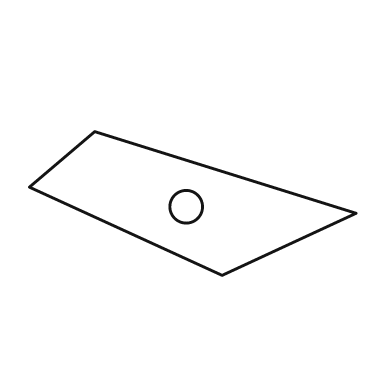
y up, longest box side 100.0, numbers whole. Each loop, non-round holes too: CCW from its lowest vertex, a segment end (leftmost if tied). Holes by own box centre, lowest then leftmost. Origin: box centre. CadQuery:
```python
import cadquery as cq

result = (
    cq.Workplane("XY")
    .moveTo(9.0, -22.0)
    .lineTo(50.0, -3.0)
    .lineTo(-30.0, 22.0)
    .lineTo(-50.0, 5.0)
    .close()
    .moveTo(-2.0, -1.0)
    .circle(5.0)
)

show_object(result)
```